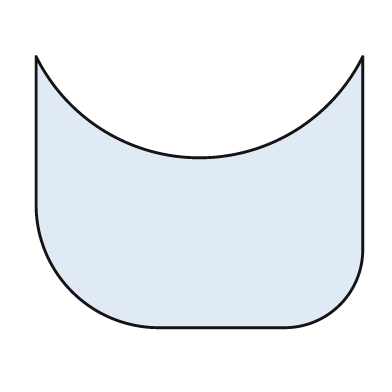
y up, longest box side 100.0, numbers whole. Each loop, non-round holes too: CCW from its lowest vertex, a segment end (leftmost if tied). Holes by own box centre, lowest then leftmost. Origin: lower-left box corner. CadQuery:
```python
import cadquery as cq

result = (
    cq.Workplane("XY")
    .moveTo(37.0, 0.0)
    .lineTo(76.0, 0.0)
    .threePointArc((93.0, 7.0), (100.0, 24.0))
    .lineTo(100.0, 83.0)
    .threePointArc((50.0, 52.0), (0.0, 83.0))
    .lineTo(0.0, 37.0)
    .threePointArc((11.0, 11.0), (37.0, 0.0))
    .close()
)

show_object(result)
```